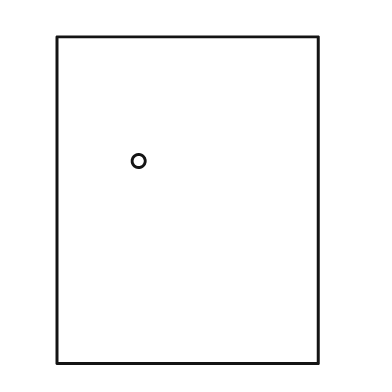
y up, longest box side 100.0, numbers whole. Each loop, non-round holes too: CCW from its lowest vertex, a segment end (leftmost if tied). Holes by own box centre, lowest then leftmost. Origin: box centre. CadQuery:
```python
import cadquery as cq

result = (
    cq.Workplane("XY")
    .moveTo(-40.0, -50.0)
    .lineTo(40.0, -50.0)
    .lineTo(40.0, 50.0)
    .lineTo(-40.0, 50.0)
    .close()
    .moveTo(-15.0, 12.0)
    .circle(2.0)
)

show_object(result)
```